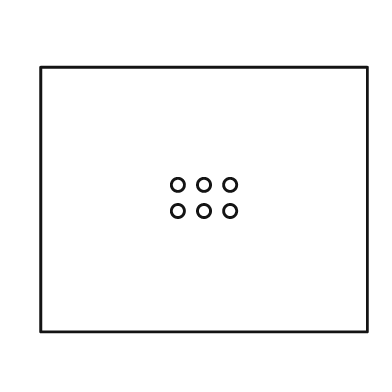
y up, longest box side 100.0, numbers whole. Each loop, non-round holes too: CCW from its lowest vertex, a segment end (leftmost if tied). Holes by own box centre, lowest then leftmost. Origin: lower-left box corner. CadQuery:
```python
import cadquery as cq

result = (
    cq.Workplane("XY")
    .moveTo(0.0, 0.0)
    .lineTo(100.0, 0.0)
    .lineTo(100.0, 81.0)
    .lineTo(0.0, 81.0)
    .close()
    .moveTo(42.0, 37.0)
    .circle(2.0)
    .moveTo(50.0, 37.0)
    .circle(2.0)
    .moveTo(58.0, 37.0)
    .circle(2.0)
    .moveTo(42.0, 45.0)
    .circle(2.0)
    .moveTo(50.0, 45.0)
    .circle(2.0)
    .moveTo(58.0, 45.0)
    .circle(2.0)
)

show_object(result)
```